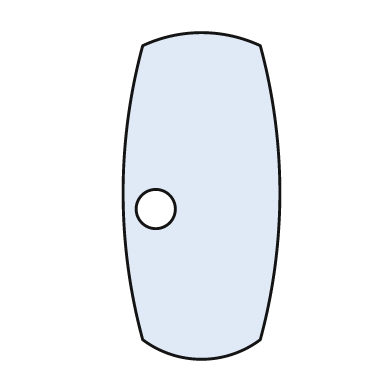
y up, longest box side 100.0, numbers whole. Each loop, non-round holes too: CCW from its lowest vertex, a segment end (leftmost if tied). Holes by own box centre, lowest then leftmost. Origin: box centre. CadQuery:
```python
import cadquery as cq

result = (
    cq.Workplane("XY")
    .moveTo(-18.0, -44.0)
    .threePointArc((0.0, -50.0), (18.0, -44.0))
    .threePointArc((24.0, 1.0), (18.0, 46.0))
    .threePointArc((0.0, 50.0), (-18.0, 46.0))
    .threePointArc((-24.0, 1.0), (-18.0, -44.0))
    .close()
    .moveTo(-14.0, -4.0)
    .circle(6.0)
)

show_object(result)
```